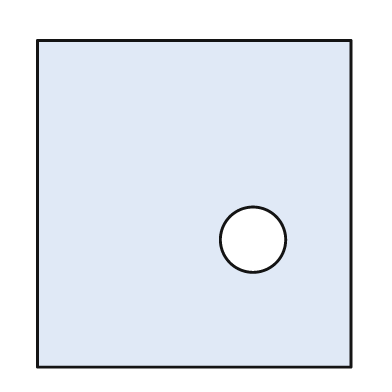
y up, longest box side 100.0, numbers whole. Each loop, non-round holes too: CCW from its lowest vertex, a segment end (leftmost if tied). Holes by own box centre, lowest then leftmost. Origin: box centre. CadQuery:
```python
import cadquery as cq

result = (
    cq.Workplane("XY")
    .moveTo(-48.0, -50.0)
    .lineTo(48.0, -50.0)
    .lineTo(48.0, 50.0)
    .lineTo(-48.0, 50.0)
    .close()
    .moveTo(18.0, -11.0)
    .circle(10.0)
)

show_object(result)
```